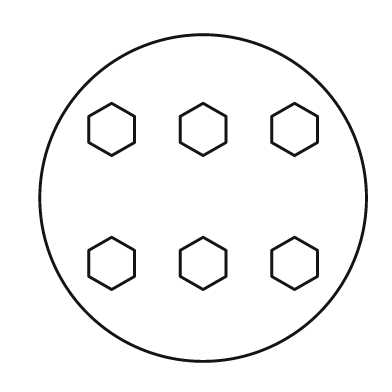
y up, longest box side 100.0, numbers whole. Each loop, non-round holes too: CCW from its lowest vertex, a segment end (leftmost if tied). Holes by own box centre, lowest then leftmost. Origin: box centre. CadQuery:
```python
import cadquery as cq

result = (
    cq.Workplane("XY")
    .moveTo(0.0, 0.0)
    .circle(50.0)
    .moveTo(-28.0, -28.0)
    .lineTo(-21.0, -24.0)
    .lineTo(-21.0, -16.0)
    .lineTo(-28.0, -12.0)
    .lineTo(-35.0, -16.0)
    .lineTo(-35.0, -24.0)
    .close()
    .moveTo(0.0, -28.0)
    .lineTo(7.0, -24.0)
    .lineTo(7.0, -16.0)
    .lineTo(0.0, -12.0)
    .lineTo(-7.0, -16.0)
    .lineTo(-7.0, -24.0)
    .close()
    .moveTo(28.0, -28.0)
    .lineTo(35.0, -24.0)
    .lineTo(35.0, -16.0)
    .lineTo(28.0, -12.0)
    .lineTo(21.0, -16.0)
    .lineTo(21.0, -24.0)
    .close()
    .moveTo(-28.0, 13.0)
    .lineTo(-21.0, 17.0)
    .lineTo(-21.0, 25.0)
    .lineTo(-28.0, 29.0)
    .lineTo(-35.0, 25.0)
    .lineTo(-35.0, 17.0)
    .close()
    .moveTo(0.0, 13.0)
    .lineTo(7.0, 17.0)
    .lineTo(7.0, 25.0)
    .lineTo(0.0, 29.0)
    .lineTo(-7.0, 25.0)
    .lineTo(-7.0, 17.0)
    .close()
    .moveTo(28.0, 13.0)
    .lineTo(35.0, 17.0)
    .lineTo(35.0, 25.0)
    .lineTo(28.0, 29.0)
    .lineTo(21.0, 25.0)
    .lineTo(21.0, 17.0)
    .close()
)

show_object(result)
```